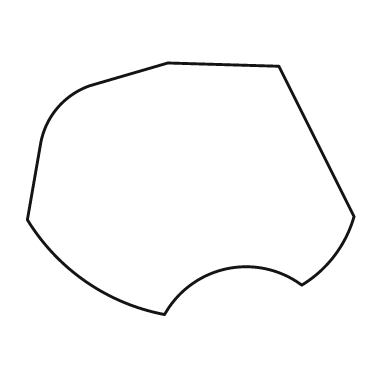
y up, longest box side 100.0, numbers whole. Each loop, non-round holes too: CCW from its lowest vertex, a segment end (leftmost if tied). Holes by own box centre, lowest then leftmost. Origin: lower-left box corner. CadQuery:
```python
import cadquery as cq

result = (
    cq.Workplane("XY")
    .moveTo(42.0, 0.0)
    .threePointArc((61.0, 14.0), (84.0, 9.0))
    .threePointArc((94.0, 18.0), (100.0, 30.0))
    .lineTo(77.0, 76.0)
    .lineTo(43.0, 77.0)
    .lineTo(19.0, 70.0)
    .threePointArc((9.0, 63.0), (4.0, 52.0))
    .lineTo(0.0, 29.0)
    .threePointArc((18.0, 10.0), (42.0, 0.0))
    .close()
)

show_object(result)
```